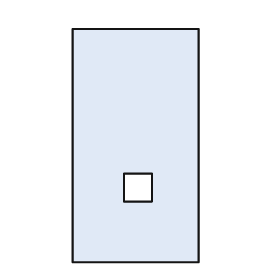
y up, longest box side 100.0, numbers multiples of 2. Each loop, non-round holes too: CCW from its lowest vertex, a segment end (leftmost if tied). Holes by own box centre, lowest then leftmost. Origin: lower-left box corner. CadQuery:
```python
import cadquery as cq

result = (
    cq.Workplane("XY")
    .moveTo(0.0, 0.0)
    .lineTo(54.0, 0.0)
    .lineTo(54.0, 100.0)
    .lineTo(0.0, 100.0)
    .close()
    .moveTo(22.0, 26.0)
    .lineTo(34.0, 26.0)
    .lineTo(34.0, 38.0)
    .lineTo(22.0, 38.0)
    .close()
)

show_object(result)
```